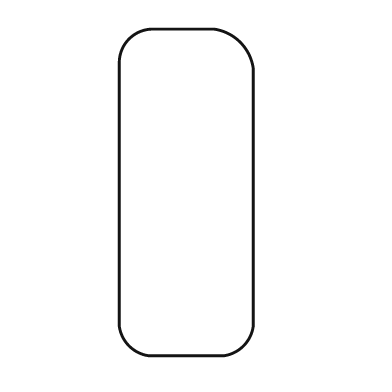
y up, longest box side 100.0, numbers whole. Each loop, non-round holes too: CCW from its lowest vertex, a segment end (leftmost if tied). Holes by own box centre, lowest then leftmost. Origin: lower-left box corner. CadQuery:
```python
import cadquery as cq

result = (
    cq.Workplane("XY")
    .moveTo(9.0, 0.0)
    .lineTo(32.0, 0.0)
    .threePointArc((38.0, 3.0), (41.0, 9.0))
    .lineTo(41.0, 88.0)
    .threePointArc((37.0, 96.0), (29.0, 100.0))
    .lineTo(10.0, 100.0)
    .threePointArc((3.0, 97.0), (0.0, 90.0))
    .lineTo(0.0, 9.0)
    .threePointArc((3.0, 3.0), (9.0, 0.0))
    .close()
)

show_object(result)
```